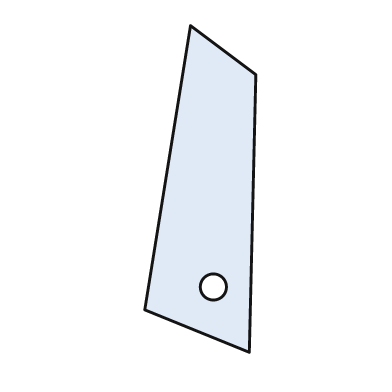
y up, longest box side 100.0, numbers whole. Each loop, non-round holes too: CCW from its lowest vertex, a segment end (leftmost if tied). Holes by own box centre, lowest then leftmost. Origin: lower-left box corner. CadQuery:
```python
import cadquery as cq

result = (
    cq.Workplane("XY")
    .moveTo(32.0, 0.0)
    .lineTo(34.0, 85.0)
    .lineTo(14.0, 100.0)
    .lineTo(0.0, 13.0)
    .close()
    .moveTo(21.0, 20.0)
    .circle(4.0)
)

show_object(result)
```